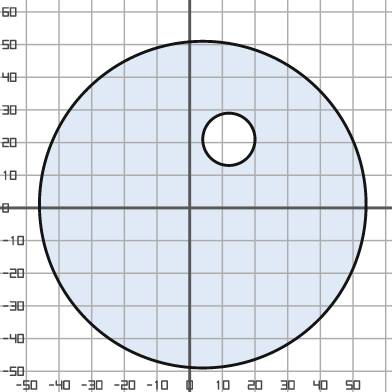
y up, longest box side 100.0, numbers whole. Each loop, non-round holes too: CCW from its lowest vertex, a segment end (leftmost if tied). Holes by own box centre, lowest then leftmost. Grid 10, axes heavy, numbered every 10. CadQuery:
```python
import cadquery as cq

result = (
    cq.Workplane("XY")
    .moveTo(4.0, 1.0)
    .circle(50.0)
    .moveTo(12.0, 21.0)
    .circle(8.0)
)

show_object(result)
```